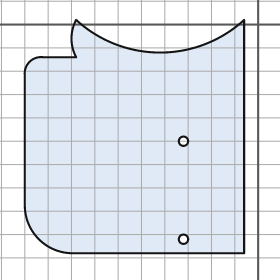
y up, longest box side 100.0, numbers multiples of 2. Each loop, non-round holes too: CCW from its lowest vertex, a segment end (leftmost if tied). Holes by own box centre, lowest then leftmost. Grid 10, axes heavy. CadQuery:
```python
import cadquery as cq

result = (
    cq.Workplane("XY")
    .moveTo(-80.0, -98.0)
    .lineTo(-6.0, -98.0)
    .lineTo(-6.0, 2.0)
    .threePointArc((-42.0, -12.0), (-78.0, 2.0))
    .threePointArc((-80.0, -6.0), (-78.0, -14.0))
    .lineTo(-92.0, -14.0)
    .threePointArc((-98.0, -16.0), (-100.0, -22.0))
    .lineTo(-100.0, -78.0)
    .threePointArc((-94.0, -92.0), (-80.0, -98.0))
    .close()
    .moveTo(-32.0, -92.0)
    .circle(2.0)
    .moveTo(-32.0, -50.0)
    .circle(2.0)
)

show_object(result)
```